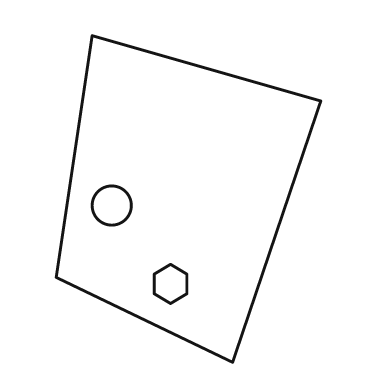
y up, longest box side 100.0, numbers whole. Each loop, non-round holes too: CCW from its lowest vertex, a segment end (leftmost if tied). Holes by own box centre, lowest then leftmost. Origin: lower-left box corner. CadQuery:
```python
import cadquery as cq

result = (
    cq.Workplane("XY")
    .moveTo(54.0, 0.0)
    .lineTo(81.0, 80.0)
    .lineTo(11.0, 100.0)
    .lineTo(0.0, 26.0)
    .close()
    .moveTo(35.0, 18.0)
    .lineTo(40.0, 21.0)
    .lineTo(40.0, 27.0)
    .lineTo(35.0, 30.0)
    .lineTo(30.0, 27.0)
    .lineTo(30.0, 21.0)
    .close()
    .moveTo(17.0, 48.0)
    .circle(6.0)
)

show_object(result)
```